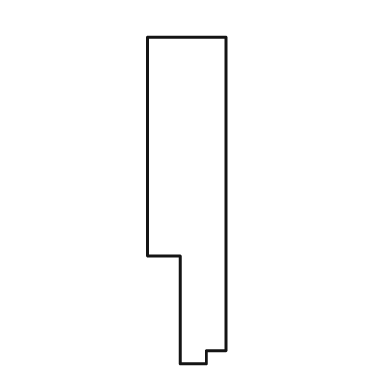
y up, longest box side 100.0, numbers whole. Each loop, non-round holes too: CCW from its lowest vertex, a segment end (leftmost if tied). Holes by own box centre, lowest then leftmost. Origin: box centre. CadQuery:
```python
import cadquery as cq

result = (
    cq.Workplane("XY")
    .moveTo(-2.0, -50.0)
    .lineTo(6.0, -50.0)
    .lineTo(6.0, -46.0)
    .lineTo(12.0, -46.0)
    .lineTo(12.0, 50.0)
    .lineTo(-12.0, 50.0)
    .lineTo(-12.0, -17.0)
    .lineTo(-2.0, -17.0)
    .close()
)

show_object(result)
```